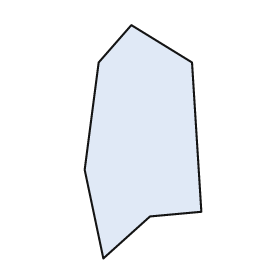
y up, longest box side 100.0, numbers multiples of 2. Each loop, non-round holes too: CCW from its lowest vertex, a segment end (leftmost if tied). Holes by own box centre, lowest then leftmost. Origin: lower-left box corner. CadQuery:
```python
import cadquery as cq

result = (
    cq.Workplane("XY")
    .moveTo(8.0, 0.0)
    .lineTo(28.0, 18.0)
    .lineTo(50.0, 20.0)
    .lineTo(46.0, 84.0)
    .lineTo(20.0, 100.0)
    .lineTo(6.0, 84.0)
    .lineTo(0.0, 38.0)
    .close()
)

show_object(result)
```